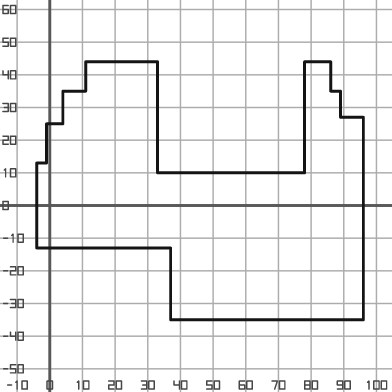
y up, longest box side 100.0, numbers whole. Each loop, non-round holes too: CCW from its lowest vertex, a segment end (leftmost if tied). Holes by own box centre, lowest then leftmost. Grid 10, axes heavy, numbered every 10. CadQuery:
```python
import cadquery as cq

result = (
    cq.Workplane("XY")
    .moveTo(37.0, -35.0)
    .lineTo(96.0, -35.0)
    .lineTo(96.0, 27.0)
    .lineTo(89.0, 27.0)
    .lineTo(89.0, 35.0)
    .lineTo(86.0, 35.0)
    .lineTo(86.0, 44.0)
    .lineTo(78.0, 44.0)
    .lineTo(78.0, 10.0)
    .lineTo(33.0, 10.0)
    .lineTo(33.0, 44.0)
    .lineTo(11.0, 44.0)
    .lineTo(11.0, 35.0)
    .lineTo(4.0, 35.0)
    .lineTo(4.0, 25.0)
    .lineTo(-1.0, 25.0)
    .lineTo(-1.0, 13.0)
    .lineTo(-4.0, 13.0)
    .lineTo(-4.0, -13.0)
    .lineTo(37.0, -13.0)
    .close()
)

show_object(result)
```